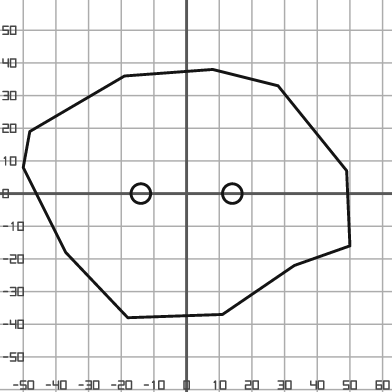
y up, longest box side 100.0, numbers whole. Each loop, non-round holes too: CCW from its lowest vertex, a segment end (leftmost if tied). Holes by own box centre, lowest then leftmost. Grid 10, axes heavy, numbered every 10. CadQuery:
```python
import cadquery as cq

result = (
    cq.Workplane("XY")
    .moveTo(-18.0, -38.0)
    .lineTo(11.0, -37.0)
    .lineTo(33.0, -22.0)
    .lineTo(50.0, -16.0)
    .lineTo(49.0, 7.0)
    .lineTo(28.0, 33.0)
    .lineTo(8.0, 38.0)
    .lineTo(-19.0, 36.0)
    .lineTo(-48.0, 19.0)
    .lineTo(-50.0, 8.0)
    .lineTo(-37.0, -18.0)
    .close()
    .moveTo(-14.0, 0.0)
    .circle(3.0)
    .moveTo(14.0, 0.0)
    .circle(3.0)
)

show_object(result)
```